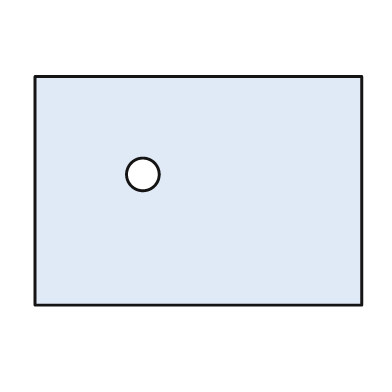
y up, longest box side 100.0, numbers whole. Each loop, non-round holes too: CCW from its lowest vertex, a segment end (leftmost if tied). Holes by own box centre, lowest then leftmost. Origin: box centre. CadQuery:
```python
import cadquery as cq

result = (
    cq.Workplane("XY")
    .moveTo(-50.0, -35.0)
    .lineTo(50.0, -35.0)
    .lineTo(50.0, 35.0)
    .lineTo(-50.0, 35.0)
    .close()
    .moveTo(-17.0, 5.0)
    .circle(5.0)
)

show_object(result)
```